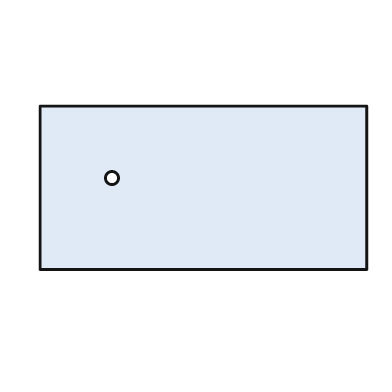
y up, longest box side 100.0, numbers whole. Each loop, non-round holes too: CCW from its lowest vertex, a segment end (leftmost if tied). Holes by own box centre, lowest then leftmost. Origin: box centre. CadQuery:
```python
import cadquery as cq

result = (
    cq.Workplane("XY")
    .moveTo(-50.0, -25.0)
    .lineTo(50.0, -25.0)
    .lineTo(50.0, 25.0)
    .lineTo(-50.0, 25.0)
    .close()
    .moveTo(-28.0, 3.0)
    .circle(2.0)
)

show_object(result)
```